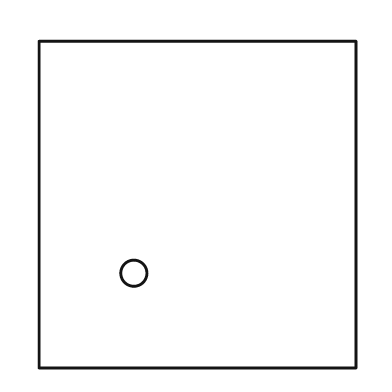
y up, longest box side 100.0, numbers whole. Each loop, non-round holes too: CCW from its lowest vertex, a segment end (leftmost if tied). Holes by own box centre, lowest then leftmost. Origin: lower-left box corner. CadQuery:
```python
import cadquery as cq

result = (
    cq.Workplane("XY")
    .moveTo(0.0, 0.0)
    .lineTo(97.0, 0.0)
    .lineTo(97.0, 100.0)
    .lineTo(0.0, 100.0)
    .close()
    .moveTo(29.0, 29.0)
    .circle(4.0)
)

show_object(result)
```